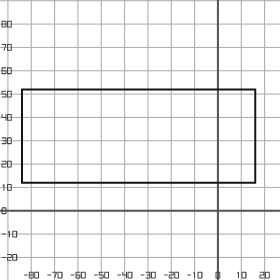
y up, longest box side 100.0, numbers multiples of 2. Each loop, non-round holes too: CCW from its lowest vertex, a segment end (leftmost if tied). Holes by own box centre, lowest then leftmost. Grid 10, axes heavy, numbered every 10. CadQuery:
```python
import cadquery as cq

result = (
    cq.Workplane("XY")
    .moveTo(-84.0, 12.0)
    .lineTo(16.0, 12.0)
    .lineTo(16.0, 52.0)
    .lineTo(-84.0, 52.0)
    .close()
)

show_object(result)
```